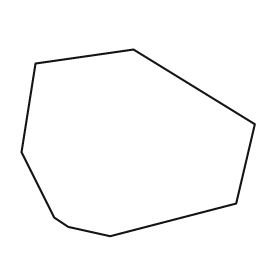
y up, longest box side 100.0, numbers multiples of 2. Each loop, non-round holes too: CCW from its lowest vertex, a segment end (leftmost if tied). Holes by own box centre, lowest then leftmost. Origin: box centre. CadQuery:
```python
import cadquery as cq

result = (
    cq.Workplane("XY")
    .moveTo(-12.0, -40.0)
    .lineTo(42.0, -26.0)
    .lineTo(50.0, 8.0)
    .lineTo(-2.0, 40.0)
    .lineTo(-44.0, 34.0)
    .lineTo(-50.0, -4.0)
    .lineTo(-36.0, -32.0)
    .lineTo(-30.0, -36.0)
    .close()
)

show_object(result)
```